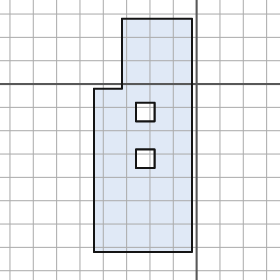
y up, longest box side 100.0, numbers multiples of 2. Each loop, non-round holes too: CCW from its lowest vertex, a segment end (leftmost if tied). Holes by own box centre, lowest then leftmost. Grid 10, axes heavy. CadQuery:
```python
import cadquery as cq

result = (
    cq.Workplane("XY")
    .moveTo(-44.0, -72.0)
    .lineTo(-2.0, -72.0)
    .lineTo(-2.0, 28.0)
    .lineTo(-32.0, 28.0)
    .lineTo(-32.0, -2.0)
    .lineTo(-44.0, -2.0)
    .close()
    .moveTo(-26.0, -36.0)
    .lineTo(-18.0, -36.0)
    .lineTo(-18.0, -28.0)
    .lineTo(-26.0, -28.0)
    .close()
    .moveTo(-26.0, -16.0)
    .lineTo(-18.0, -16.0)
    .lineTo(-18.0, -8.0)
    .lineTo(-26.0, -8.0)
    .close()
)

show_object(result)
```